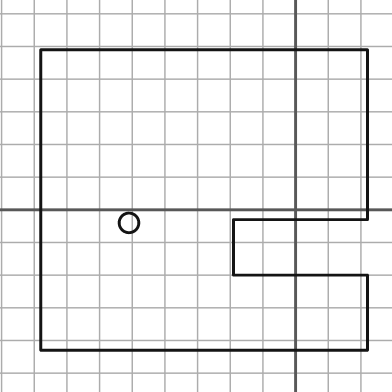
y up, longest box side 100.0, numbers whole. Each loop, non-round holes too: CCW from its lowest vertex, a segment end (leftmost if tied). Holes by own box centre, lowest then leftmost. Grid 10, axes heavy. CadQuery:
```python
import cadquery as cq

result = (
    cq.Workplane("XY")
    .moveTo(-78.0, -43.0)
    .lineTo(22.0, -43.0)
    .lineTo(22.0, -20.0)
    .lineTo(-19.0, -20.0)
    .lineTo(-19.0, -3.0)
    .lineTo(22.0, -3.0)
    .lineTo(22.0, 49.0)
    .lineTo(-78.0, 49.0)
    .close()
    .moveTo(-51.0, -4.0)
    .circle(3.0)
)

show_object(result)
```